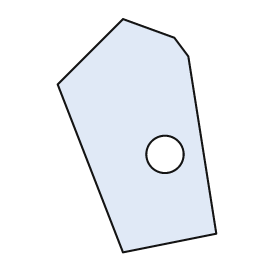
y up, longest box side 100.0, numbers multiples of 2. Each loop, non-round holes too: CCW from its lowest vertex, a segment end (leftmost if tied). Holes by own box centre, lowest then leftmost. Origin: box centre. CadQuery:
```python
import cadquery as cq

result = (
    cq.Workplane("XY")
    .moveTo(-6.0, -50.0)
    .lineTo(34.0, -42.0)
    .lineTo(22.0, 34.0)
    .lineTo(16.0, 42.0)
    .lineTo(-6.0, 50.0)
    .lineTo(-34.0, 22.0)
    .close()
    .moveTo(12.0, -8.0)
    .circle(8.0)
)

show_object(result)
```